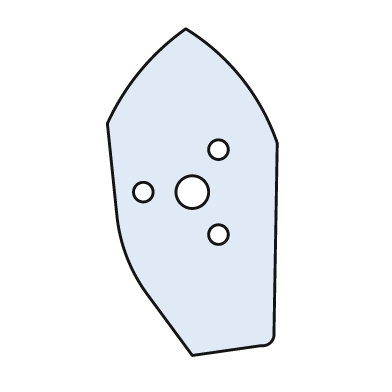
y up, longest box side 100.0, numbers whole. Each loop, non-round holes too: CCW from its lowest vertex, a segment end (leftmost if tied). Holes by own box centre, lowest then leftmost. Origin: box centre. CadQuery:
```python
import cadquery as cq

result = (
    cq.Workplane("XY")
    .moveTo(0.0, -50.0)
    .lineTo(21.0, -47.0)
    .threePointArc((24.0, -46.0), (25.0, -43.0))
    .lineTo(26.0, 15.0)
    .threePointArc((15.0, 35.0), (-2.0, 50.0))
    .threePointArc((-16.0, 37.0), (-26.0, 21.0))
    .lineTo(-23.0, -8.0)
    .threePointArc((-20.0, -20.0), (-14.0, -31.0))
    .close()
    .moveTo(8.0, -13.0)
    .circle(3.0)
    .moveTo(-15.0, 0.0)
    .circle(3.0)
    .moveTo(0.0, 0.0)
    .circle(5.0)
    .moveTo(8.0, 13.0)
    .circle(3.0)
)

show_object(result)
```